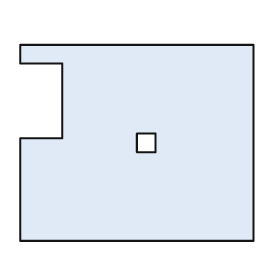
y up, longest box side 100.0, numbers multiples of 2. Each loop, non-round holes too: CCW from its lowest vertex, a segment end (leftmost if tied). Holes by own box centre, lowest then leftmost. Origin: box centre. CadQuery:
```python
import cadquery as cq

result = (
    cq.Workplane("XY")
    .moveTo(-50.0, -42.0)
    .lineTo(50.0, -42.0)
    .lineTo(50.0, 42.0)
    .lineTo(-50.0, 42.0)
    .lineTo(-50.0, 34.0)
    .lineTo(-32.0, 34.0)
    .lineTo(-32.0, 2.0)
    .lineTo(-50.0, 2.0)
    .close()
    .moveTo(0.0, -4.0)
    .lineTo(8.0, -4.0)
    .lineTo(8.0, 4.0)
    .lineTo(0.0, 4.0)
    .close()
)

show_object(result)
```